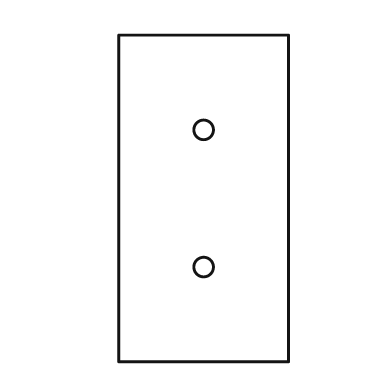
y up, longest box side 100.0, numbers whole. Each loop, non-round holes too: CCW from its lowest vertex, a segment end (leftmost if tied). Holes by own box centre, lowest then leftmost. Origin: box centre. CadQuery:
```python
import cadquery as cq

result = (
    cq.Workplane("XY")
    .moveTo(-26.0, -50.0)
    .lineTo(26.0, -50.0)
    .lineTo(26.0, 50.0)
    .lineTo(-26.0, 50.0)
    .close()
    .moveTo(0.0, -21.0)
    .circle(3.0)
    .moveTo(0.0, 21.0)
    .circle(3.0)
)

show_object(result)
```